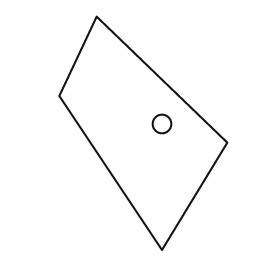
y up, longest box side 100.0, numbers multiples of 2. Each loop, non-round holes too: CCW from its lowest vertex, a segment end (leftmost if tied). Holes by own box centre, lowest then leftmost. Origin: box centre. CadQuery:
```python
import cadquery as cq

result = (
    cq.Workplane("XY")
    .moveTo(8.0, -50.0)
    .lineTo(36.0, -4.0)
    .lineTo(-20.0, 50.0)
    .lineTo(-36.0, 16.0)
    .close()
    .moveTo(8.0, 4.0)
    .circle(4.0)
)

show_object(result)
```